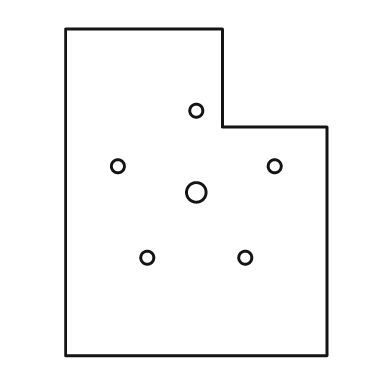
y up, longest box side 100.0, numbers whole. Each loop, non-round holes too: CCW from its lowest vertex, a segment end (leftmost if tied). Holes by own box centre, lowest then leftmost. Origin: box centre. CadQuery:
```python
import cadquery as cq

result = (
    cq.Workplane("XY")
    .moveTo(-40.0, -50.0)
    .lineTo(40.0, -50.0)
    .lineTo(40.0, 20.0)
    .lineTo(8.0, 20.0)
    .lineTo(8.0, 50.0)
    .lineTo(-40.0, 50.0)
    .close()
    .moveTo(-15.0, -20.0)
    .circle(2.0)
    .moveTo(15.0, -20.0)
    .circle(2.0)
    .moveTo(0.0, 0.0)
    .circle(3.0)
    .moveTo(-24.0, 8.0)
    .circle(2.0)
    .moveTo(24.0, 8.0)
    .circle(2.0)
    .moveTo(0.0, 25.0)
    .circle(2.0)
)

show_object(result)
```